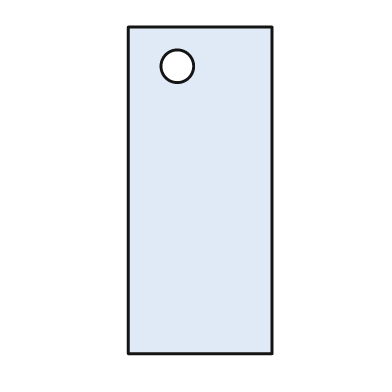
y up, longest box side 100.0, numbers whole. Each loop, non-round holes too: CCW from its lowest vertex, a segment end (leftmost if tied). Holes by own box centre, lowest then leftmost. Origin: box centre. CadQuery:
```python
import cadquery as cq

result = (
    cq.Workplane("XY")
    .moveTo(-22.0, -50.0)
    .lineTo(22.0, -50.0)
    .lineTo(22.0, 50.0)
    .lineTo(-22.0, 50.0)
    .close()
    .moveTo(-7.0, 38.0)
    .circle(5.0)
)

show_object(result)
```